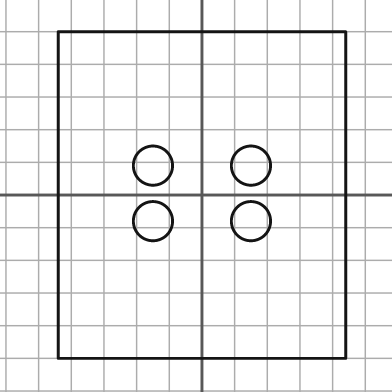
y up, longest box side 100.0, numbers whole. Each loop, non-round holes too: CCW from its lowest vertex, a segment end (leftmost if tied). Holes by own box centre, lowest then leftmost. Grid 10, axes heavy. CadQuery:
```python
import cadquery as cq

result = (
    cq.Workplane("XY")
    .moveTo(-44.0, -50.0)
    .lineTo(44.0, -50.0)
    .lineTo(44.0, 50.0)
    .lineTo(-44.0, 50.0)
    .close()
    .moveTo(-15.0, -8.0)
    .circle(6.0)
    .moveTo(15.0, -8.0)
    .circle(6.0)
    .moveTo(-15.0, 9.0)
    .circle(6.0)
    .moveTo(15.0, 9.0)
    .circle(6.0)
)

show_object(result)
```